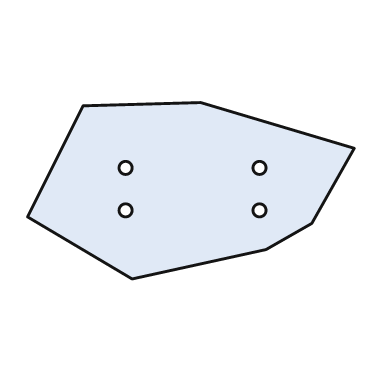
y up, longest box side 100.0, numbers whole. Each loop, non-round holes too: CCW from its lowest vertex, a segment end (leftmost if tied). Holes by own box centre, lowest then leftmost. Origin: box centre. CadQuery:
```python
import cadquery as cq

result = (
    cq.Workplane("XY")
    .moveTo(-18.0, -27.0)
    .lineTo(23.0, -18.0)
    .lineTo(37.0, -10.0)
    .lineTo(50.0, 13.0)
    .lineTo(3.0, 27.0)
    .lineTo(-33.0, 26.0)
    .lineTo(-50.0, -8.0)
    .close()
    .moveTo(-20.0, -6.0)
    .circle(2.0)
    .moveTo(21.0, -6.0)
    .circle(2.0)
    .moveTo(-20.0, 7.0)
    .circle(2.0)
    .moveTo(21.0, 7.0)
    .circle(2.0)
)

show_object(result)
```